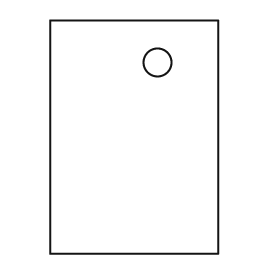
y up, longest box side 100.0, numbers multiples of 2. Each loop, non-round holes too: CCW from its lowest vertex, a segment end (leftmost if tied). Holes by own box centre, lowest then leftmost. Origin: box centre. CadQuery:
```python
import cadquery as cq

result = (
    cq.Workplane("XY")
    .moveTo(-36.0, -50.0)
    .lineTo(36.0, -50.0)
    .lineTo(36.0, 50.0)
    .lineTo(-36.0, 50.0)
    .close()
    .moveTo(10.0, 32.0)
    .circle(6.0)
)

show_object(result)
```